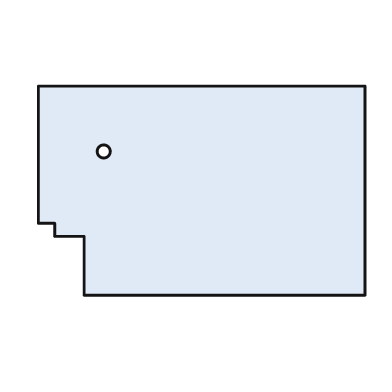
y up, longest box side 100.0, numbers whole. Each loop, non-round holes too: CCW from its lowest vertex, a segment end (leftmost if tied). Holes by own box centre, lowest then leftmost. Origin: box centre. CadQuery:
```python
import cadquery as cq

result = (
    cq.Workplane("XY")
    .moveTo(-36.0, -32.0)
    .lineTo(50.0, -32.0)
    .lineTo(50.0, 32.0)
    .lineTo(-50.0, 32.0)
    .lineTo(-50.0, -10.0)
    .lineTo(-45.0, -10.0)
    .lineTo(-45.0, -14.0)
    .lineTo(-36.0, -14.0)
    .close()
    .moveTo(-30.0, 12.0)
    .circle(2.0)
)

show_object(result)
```